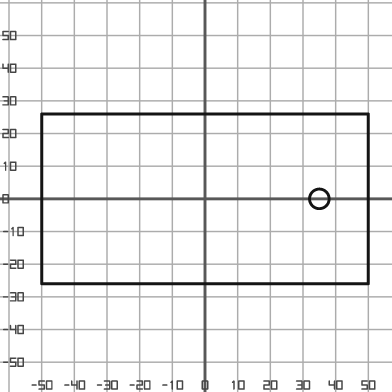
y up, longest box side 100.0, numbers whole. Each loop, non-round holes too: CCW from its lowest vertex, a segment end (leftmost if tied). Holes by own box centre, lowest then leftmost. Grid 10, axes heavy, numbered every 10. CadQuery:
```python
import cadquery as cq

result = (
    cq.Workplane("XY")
    .moveTo(-50.0, -26.0)
    .lineTo(50.0, -26.0)
    .lineTo(50.0, 26.0)
    .lineTo(-50.0, 26.0)
    .close()
    .moveTo(35.0, 0.0)
    .circle(3.0)
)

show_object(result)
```